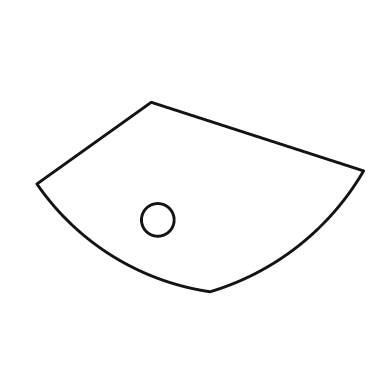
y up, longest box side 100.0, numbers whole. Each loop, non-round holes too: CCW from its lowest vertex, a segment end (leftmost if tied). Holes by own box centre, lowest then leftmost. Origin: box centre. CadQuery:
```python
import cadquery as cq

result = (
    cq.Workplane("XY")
    .moveTo(3.0, -29.0)
    .threePointArc((30.0, -15.0), (50.0, 8.0))
    .lineTo(-15.0, 29.0)
    .lineTo(-50.0, 4.0)
    .threePointArc((-27.0, -18.0), (3.0, -29.0))
    .close()
    .moveTo(-13.0, -7.0)
    .circle(5.0)
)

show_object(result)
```